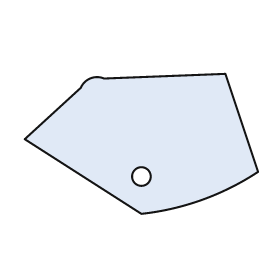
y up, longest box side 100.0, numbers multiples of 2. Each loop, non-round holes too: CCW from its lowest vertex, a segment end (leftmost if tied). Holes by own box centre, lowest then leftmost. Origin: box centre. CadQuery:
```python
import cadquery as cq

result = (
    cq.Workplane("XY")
    .moveTo(0.0, -30.0)
    .threePointArc((26.0, -24.0), (50.0, -12.0))
    .lineTo(36.0, 30.0)
    .lineTo(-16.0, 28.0)
    .threePointArc((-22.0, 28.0), (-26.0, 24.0))
    .lineTo(-50.0, 2.0)
    .close()
    .moveTo(0.0, -14.0)
    .circle(4.0)
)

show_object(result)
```